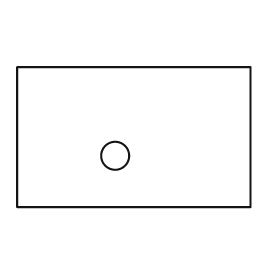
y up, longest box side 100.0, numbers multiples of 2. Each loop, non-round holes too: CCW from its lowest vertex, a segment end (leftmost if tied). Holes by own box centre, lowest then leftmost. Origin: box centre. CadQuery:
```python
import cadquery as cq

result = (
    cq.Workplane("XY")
    .moveTo(-50.0, -30.0)
    .lineTo(50.0, -30.0)
    .lineTo(50.0, 30.0)
    .lineTo(-50.0, 30.0)
    .close()
    .moveTo(-8.0, -8.0)
    .circle(6.0)
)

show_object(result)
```